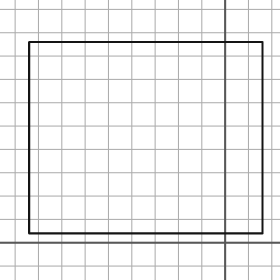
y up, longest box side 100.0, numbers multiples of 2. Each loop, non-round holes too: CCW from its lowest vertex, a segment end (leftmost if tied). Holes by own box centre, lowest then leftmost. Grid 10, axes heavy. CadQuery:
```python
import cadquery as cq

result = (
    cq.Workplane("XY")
    .moveTo(-84.0, 4.0)
    .lineTo(16.0, 4.0)
    .lineTo(16.0, 86.0)
    .lineTo(-84.0, 86.0)
    .close()
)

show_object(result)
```